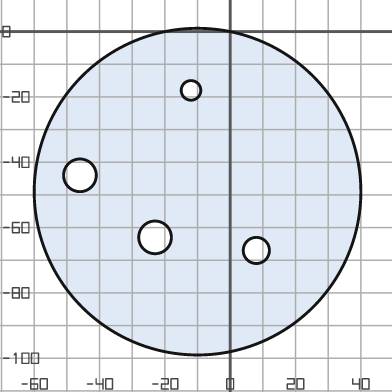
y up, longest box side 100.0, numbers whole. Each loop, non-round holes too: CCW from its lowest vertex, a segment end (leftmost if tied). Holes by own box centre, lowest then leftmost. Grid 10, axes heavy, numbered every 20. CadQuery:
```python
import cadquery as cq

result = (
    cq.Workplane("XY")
    .moveTo(-10.0, -49.0)
    .circle(50.0)
    .moveTo(8.0, -67.0)
    .circle(4.0)
    .moveTo(-23.0, -63.0)
    .circle(5.0)
    .moveTo(-46.0, -44.0)
    .circle(5.0)
    .moveTo(-12.0, -18.0)
    .circle(3.0)
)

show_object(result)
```